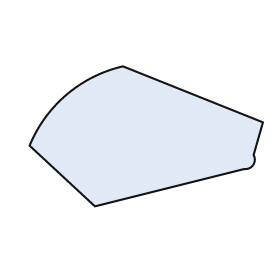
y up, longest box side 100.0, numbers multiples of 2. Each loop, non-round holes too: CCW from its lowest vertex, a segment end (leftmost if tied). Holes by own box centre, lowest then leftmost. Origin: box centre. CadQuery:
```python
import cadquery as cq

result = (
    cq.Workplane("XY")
    .moveTo(-22.0, -30.0)
    .lineTo(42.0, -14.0)
    .threePointArc((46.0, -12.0), (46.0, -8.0))
    .lineTo(50.0, 6.0)
    .lineTo(-10.0, 30.0)
    .threePointArc((-34.0, 18.0), (-50.0, -4.0))
    .close()
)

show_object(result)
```